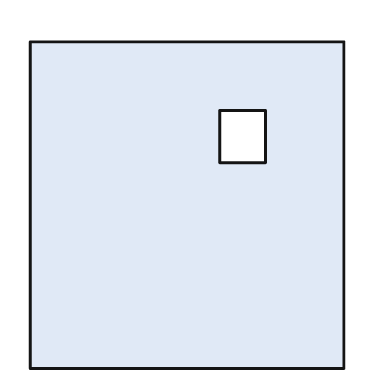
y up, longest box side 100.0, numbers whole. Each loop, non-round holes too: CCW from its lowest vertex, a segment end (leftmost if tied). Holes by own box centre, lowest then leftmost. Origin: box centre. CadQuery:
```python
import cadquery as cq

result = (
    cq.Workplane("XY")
    .moveTo(-48.0, -50.0)
    .lineTo(48.0, -50.0)
    .lineTo(48.0, 50.0)
    .lineTo(-48.0, 50.0)
    .close()
    .moveTo(10.0, 13.0)
    .lineTo(24.0, 13.0)
    .lineTo(24.0, 29.0)
    .lineTo(10.0, 29.0)
    .close()
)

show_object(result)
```